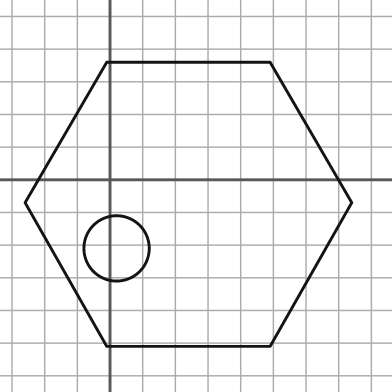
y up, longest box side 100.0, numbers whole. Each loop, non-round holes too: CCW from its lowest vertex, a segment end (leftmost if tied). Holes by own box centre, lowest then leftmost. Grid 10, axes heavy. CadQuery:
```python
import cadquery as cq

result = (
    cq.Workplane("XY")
    .moveTo(-1.0, -51.0)
    .lineTo(49.0, -51.0)
    .lineTo(74.0, -7.0)
    .lineTo(49.0, 36.0)
    .lineTo(-1.0, 36.0)
    .lineTo(-26.0, -7.0)
    .close()
    .moveTo(2.0, -21.0)
    .circle(10.0)
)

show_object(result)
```